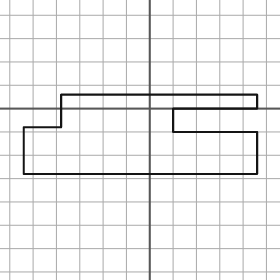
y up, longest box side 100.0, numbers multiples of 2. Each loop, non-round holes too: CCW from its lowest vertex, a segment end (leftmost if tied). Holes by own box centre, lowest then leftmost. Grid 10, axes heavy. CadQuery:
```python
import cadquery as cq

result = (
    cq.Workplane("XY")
    .moveTo(-54.0, -28.0)
    .lineTo(46.0, -28.0)
    .lineTo(46.0, -10.0)
    .lineTo(10.0, -10.0)
    .lineTo(10.0, 0.0)
    .lineTo(46.0, 0.0)
    .lineTo(46.0, 6.0)
    .lineTo(-38.0, 6.0)
    .lineTo(-38.0, -8.0)
    .lineTo(-54.0, -8.0)
    .close()
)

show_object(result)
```